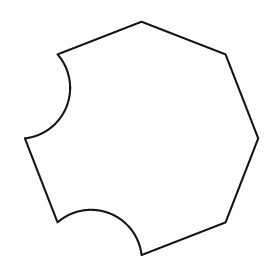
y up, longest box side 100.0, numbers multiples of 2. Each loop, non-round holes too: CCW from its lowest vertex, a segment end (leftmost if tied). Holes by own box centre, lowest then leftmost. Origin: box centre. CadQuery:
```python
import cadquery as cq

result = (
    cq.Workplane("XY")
    .moveTo(0.0, -50.0)
    .lineTo(36.0, -36.0)
    .lineTo(50.0, 0.0)
    .lineTo(36.0, 36.0)
    .lineTo(0.0, 50.0)
    .lineTo(-36.0, 36.0)
    .threePointArc((-32.0, 14.0), (-50.0, 0.0))
    .lineTo(-36.0, -36.0)
    .threePointArc((-14.0, -32.0), (0.0, -50.0))
    .close()
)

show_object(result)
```